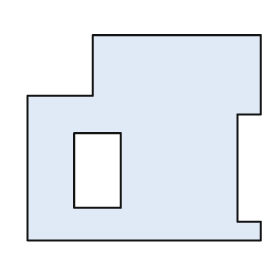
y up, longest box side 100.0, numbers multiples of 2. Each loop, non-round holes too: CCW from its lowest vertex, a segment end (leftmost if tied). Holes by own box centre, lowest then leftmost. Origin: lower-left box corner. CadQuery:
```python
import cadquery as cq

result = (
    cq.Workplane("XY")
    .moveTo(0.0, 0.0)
    .lineTo(100.0, 0.0)
    .lineTo(100.0, 8.0)
    .lineTo(90.0, 8.0)
    .lineTo(90.0, 54.0)
    .lineTo(100.0, 54.0)
    .lineTo(100.0, 88.0)
    .lineTo(28.0, 88.0)
    .lineTo(28.0, 62.0)
    .lineTo(0.0, 62.0)
    .close()
    .moveTo(20.0, 14.0)
    .lineTo(40.0, 14.0)
    .lineTo(40.0, 46.0)
    .lineTo(20.0, 46.0)
    .close()
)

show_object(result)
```